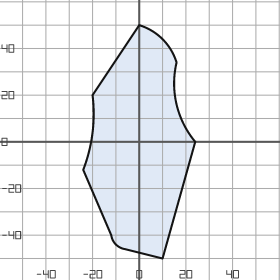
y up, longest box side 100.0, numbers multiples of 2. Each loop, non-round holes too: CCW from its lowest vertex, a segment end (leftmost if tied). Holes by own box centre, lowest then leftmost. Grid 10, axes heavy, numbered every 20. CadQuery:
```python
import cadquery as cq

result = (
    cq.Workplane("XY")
    .moveTo(10.0, -50.0)
    .lineTo(24.0, 0.0)
    .threePointArc((16.0, 16.0), (16.0, 34.0))
    .threePointArc((10.0, 44.0), (0.0, 50.0))
    .lineTo(-20.0, 20.0)
    .threePointArc((-20.0, 4.0), (-24.0, -12.0))
    .lineTo(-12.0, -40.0)
    .threePointArc((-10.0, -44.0), (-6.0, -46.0))
    .close()
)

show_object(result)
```